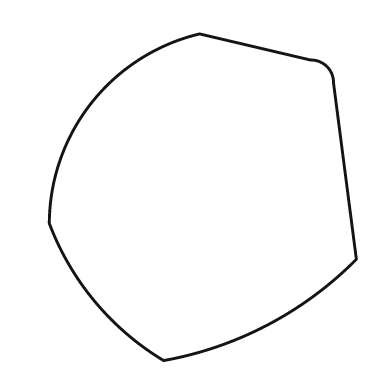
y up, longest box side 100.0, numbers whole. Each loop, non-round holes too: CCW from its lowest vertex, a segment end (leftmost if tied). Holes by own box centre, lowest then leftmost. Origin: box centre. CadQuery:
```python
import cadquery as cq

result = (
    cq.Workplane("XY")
    .moveTo(-12.0, -50.0)
    .threePointArc((20.0, -39.0), (47.0, -19.0))
    .lineTo(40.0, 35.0)
    .threePointArc((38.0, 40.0), (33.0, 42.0))
    .lineTo(-1.0, 50.0)
    .threePointArc((-34.0, 29.0), (-47.0, -8.0))
    .threePointArc((-33.0, -32.0), (-12.0, -50.0))
    .close()
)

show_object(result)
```